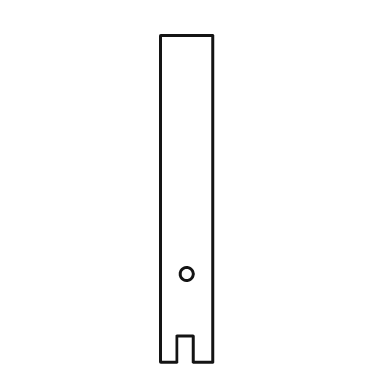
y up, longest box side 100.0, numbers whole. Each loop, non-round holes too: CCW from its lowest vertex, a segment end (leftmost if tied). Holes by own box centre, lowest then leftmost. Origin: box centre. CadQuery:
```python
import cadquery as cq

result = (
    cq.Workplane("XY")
    .moveTo(-8.0, -50.0)
    .lineTo(-3.0, -50.0)
    .lineTo(-3.0, -42.0)
    .lineTo(2.0, -42.0)
    .lineTo(2.0, -50.0)
    .lineTo(8.0, -50.0)
    .lineTo(8.0, 50.0)
    .lineTo(-8.0, 50.0)
    .close()
    .moveTo(0.0, -23.0)
    .circle(2.0)
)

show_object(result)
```